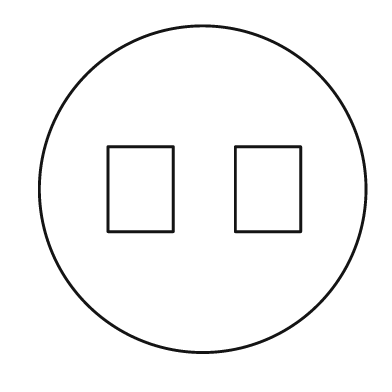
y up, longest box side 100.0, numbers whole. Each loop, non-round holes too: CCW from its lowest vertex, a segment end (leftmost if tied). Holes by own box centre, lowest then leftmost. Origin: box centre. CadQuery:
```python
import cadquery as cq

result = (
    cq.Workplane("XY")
    .moveTo(0.0, 0.0)
    .circle(50.0)
    .moveTo(-29.0, -13.0)
    .lineTo(-9.0, -13.0)
    .lineTo(-9.0, 13.0)
    .lineTo(-29.0, 13.0)
    .close()
    .moveTo(10.0, -13.0)
    .lineTo(30.0, -13.0)
    .lineTo(30.0, 13.0)
    .lineTo(10.0, 13.0)
    .close()
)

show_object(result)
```